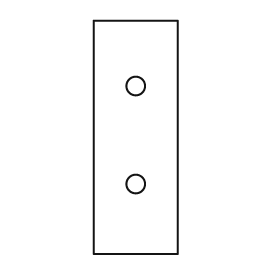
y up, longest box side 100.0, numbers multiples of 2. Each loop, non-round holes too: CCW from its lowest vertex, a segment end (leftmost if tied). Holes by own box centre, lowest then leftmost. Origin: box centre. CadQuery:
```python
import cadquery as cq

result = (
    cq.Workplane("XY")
    .moveTo(-18.0, -50.0)
    .lineTo(18.0, -50.0)
    .lineTo(18.0, 50.0)
    .lineTo(-18.0, 50.0)
    .close()
    .moveTo(0.0, -20.0)
    .circle(4.0)
    .moveTo(0.0, 22.0)
    .circle(4.0)
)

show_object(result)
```